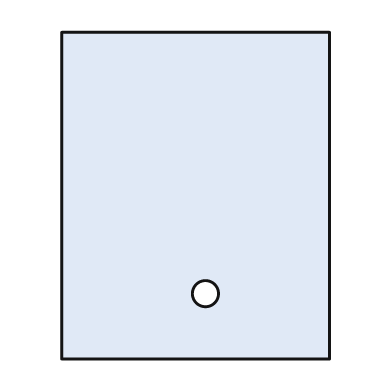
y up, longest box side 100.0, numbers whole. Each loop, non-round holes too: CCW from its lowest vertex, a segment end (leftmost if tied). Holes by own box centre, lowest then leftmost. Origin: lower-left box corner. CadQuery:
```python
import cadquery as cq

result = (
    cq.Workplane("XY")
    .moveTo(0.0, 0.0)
    .lineTo(82.0, 0.0)
    .lineTo(82.0, 100.0)
    .lineTo(0.0, 100.0)
    .close()
    .moveTo(44.0, 20.0)
    .circle(4.0)
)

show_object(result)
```